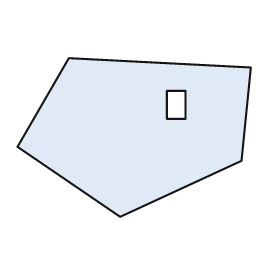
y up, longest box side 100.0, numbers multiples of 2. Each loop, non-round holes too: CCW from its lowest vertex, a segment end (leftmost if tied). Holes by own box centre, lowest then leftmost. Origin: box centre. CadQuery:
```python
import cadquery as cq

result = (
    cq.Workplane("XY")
    .moveTo(-6.0, -34.0)
    .lineTo(46.0, -10.0)
    .lineTo(50.0, 30.0)
    .lineTo(-28.0, 34.0)
    .lineTo(-50.0, -4.0)
    .close()
    .moveTo(14.0, 8.0)
    .lineTo(22.0, 8.0)
    .lineTo(22.0, 20.0)
    .lineTo(14.0, 20.0)
    .close()
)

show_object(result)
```